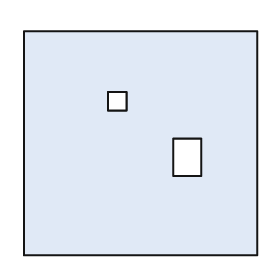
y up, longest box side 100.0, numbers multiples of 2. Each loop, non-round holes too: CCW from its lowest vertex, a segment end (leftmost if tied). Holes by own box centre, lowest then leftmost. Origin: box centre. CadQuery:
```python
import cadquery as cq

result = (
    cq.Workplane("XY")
    .moveTo(-50.0, -48.0)
    .lineTo(50.0, -48.0)
    .lineTo(50.0, 48.0)
    .lineTo(-50.0, 48.0)
    .close()
    .moveTo(14.0, -14.0)
    .lineTo(26.0, -14.0)
    .lineTo(26.0, 2.0)
    .lineTo(14.0, 2.0)
    .close()
    .moveTo(-14.0, 14.0)
    .lineTo(-6.0, 14.0)
    .lineTo(-6.0, 22.0)
    .lineTo(-14.0, 22.0)
    .close()
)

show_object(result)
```